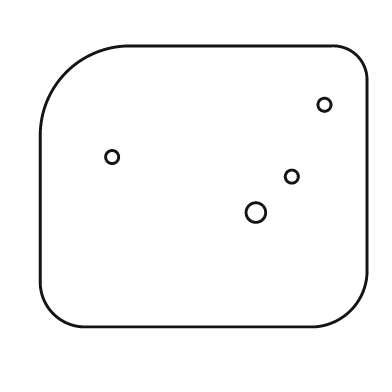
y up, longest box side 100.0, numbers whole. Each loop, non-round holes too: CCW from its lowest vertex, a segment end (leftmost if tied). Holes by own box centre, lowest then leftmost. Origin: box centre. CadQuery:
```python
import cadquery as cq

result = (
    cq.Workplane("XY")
    .moveTo(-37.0, -43.0)
    .lineTo(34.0, -43.0)
    .threePointArc((45.0, -38.0), (50.0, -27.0))
    .lineTo(50.0, 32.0)
    .threePointArc((47.0, 40.0), (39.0, 43.0))
    .lineTo(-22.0, 43.0)
    .threePointArc((-42.0, 35.0), (-50.0, 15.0))
    .lineTo(-50.0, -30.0)
    .threePointArc((-46.0, -39.0), (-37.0, -43.0))
    .close()
    .moveTo(16.0, -8.0)
    .circle(3.0)
    .moveTo(27.0, 3.0)
    .circle(2.0)
    .moveTo(-28.0, 9.0)
    .circle(2.0)
    .moveTo(37.0, 25.0)
    .circle(2.0)
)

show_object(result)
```